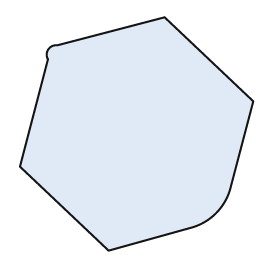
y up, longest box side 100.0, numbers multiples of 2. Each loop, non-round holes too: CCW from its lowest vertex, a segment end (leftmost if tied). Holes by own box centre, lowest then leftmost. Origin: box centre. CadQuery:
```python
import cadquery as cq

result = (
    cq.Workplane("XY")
    .moveTo(-12.0, -50.0)
    .lineTo(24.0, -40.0)
    .threePointArc((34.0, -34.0), (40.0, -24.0))
    .lineTo(50.0, 14.0)
    .lineTo(12.0, 50.0)
    .lineTo(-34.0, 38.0)
    .threePointArc((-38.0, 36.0), (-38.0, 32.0))
    .lineTo(-50.0, -14.0)
    .close()
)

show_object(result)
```